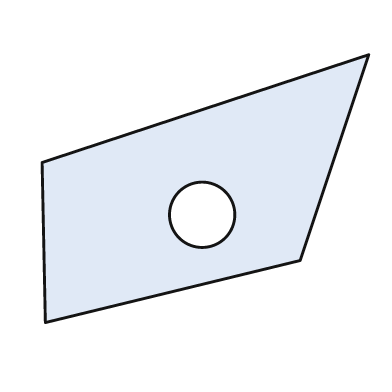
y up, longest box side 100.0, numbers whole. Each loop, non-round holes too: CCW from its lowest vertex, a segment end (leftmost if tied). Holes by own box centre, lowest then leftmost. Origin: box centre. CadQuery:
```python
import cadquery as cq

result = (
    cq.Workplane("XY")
    .moveTo(-49.0, -41.0)
    .lineTo(29.0, -22.0)
    .lineTo(50.0, 41.0)
    .lineTo(-50.0, 8.0)
    .close()
    .moveTo(-1.0, -8.0)
    .circle(10.0)
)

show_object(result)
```